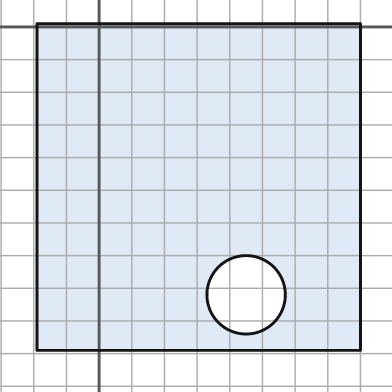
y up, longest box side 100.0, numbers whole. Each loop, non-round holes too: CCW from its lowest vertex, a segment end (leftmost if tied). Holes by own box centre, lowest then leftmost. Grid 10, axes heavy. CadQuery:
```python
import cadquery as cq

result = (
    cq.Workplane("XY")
    .moveTo(-19.0, -99.0)
    .lineTo(80.0, -99.0)
    .lineTo(80.0, 1.0)
    .lineTo(-19.0, 1.0)
    .close()
    .moveTo(45.0, -82.0)
    .circle(12.0)
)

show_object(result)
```